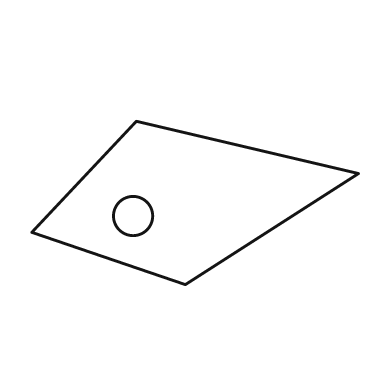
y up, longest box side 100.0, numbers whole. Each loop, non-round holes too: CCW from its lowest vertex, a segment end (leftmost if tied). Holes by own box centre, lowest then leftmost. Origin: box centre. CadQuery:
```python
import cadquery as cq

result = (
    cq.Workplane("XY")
    .moveTo(-3.0, -25.0)
    .lineTo(50.0, 9.0)
    .lineTo(-18.0, 25.0)
    .lineTo(-50.0, -9.0)
    .close()
    .moveTo(-19.0, -4.0)
    .circle(6.0)
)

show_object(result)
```